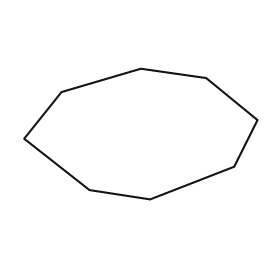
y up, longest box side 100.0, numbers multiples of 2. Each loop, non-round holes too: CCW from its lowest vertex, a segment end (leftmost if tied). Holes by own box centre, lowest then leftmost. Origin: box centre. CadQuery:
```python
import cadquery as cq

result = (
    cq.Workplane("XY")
    .moveTo(4.0, -28.0)
    .lineTo(40.0, -14.0)
    .lineTo(50.0, 6.0)
    .lineTo(28.0, 24.0)
    .lineTo(0.0, 28.0)
    .lineTo(-34.0, 18.0)
    .lineTo(-50.0, -2.0)
    .lineTo(-22.0, -24.0)
    .close()
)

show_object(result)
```